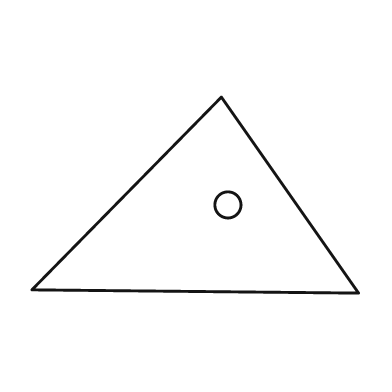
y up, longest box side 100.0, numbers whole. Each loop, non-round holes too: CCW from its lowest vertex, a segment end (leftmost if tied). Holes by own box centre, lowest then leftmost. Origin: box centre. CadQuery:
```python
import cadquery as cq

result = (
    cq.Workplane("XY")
    .moveTo(50.0, -30.0)
    .lineTo(8.0, 30.0)
    .lineTo(-50.0, -29.0)
    .close()
    .moveTo(10.0, -3.0)
    .circle(4.0)
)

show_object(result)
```